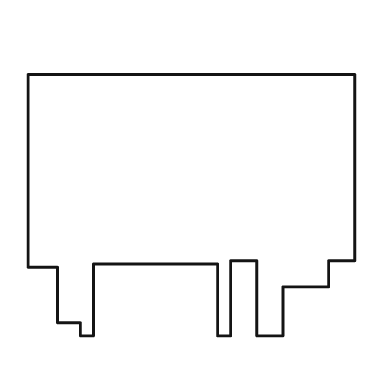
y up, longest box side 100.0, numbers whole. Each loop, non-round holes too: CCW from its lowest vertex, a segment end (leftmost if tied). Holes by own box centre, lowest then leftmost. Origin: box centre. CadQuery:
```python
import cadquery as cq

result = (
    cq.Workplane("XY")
    .moveTo(-34.0, -40.0)
    .lineTo(-30.0, -40.0)
    .lineTo(-30.0, -18.0)
    .lineTo(8.0, -18.0)
    .lineTo(8.0, -40.0)
    .lineTo(12.0, -40.0)
    .lineTo(12.0, -17.0)
    .lineTo(20.0, -17.0)
    .lineTo(20.0, -40.0)
    .lineTo(28.0, -40.0)
    .lineTo(28.0, -25.0)
    .lineTo(42.0, -25.0)
    .lineTo(42.0, -17.0)
    .lineTo(50.0, -17.0)
    .lineTo(50.0, 40.0)
    .lineTo(-50.0, 40.0)
    .lineTo(-50.0, -19.0)
    .lineTo(-41.0, -19.0)
    .lineTo(-41.0, -36.0)
    .lineTo(-34.0, -36.0)
    .close()
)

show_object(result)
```